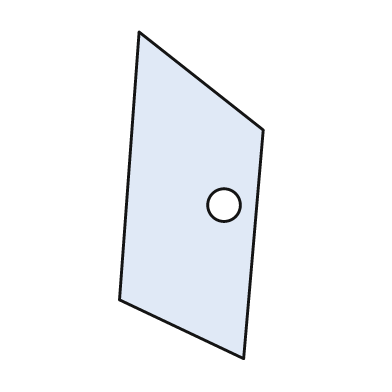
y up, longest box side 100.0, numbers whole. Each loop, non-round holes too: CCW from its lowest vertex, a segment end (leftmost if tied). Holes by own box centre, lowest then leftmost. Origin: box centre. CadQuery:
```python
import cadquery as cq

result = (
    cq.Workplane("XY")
    .moveTo(16.0, -50.0)
    .lineTo(22.0, 20.0)
    .lineTo(-16.0, 50.0)
    .lineTo(-22.0, -32.0)
    .close()
    .moveTo(10.0, -3.0)
    .circle(5.0)
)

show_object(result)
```